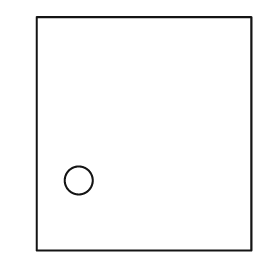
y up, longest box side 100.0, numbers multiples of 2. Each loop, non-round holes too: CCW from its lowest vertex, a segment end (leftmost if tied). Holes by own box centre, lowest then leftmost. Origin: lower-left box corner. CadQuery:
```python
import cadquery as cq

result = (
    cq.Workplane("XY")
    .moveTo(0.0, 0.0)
    .lineTo(92.0, 0.0)
    .lineTo(92.0, 100.0)
    .lineTo(0.0, 100.0)
    .close()
    .moveTo(18.0, 30.0)
    .circle(6.0)
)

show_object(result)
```